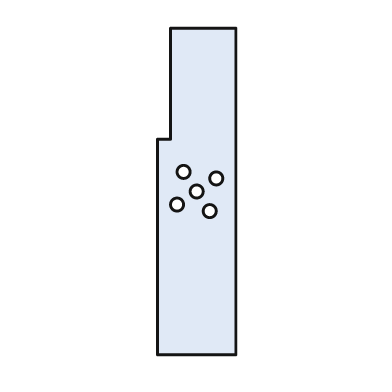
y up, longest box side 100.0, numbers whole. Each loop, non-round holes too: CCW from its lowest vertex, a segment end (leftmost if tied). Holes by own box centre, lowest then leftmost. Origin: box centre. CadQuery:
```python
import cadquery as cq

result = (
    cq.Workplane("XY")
    .moveTo(-12.0, -50.0)
    .lineTo(12.0, -50.0)
    .lineTo(12.0, 50.0)
    .lineTo(-8.0, 50.0)
    .lineTo(-8.0, 16.0)
    .lineTo(-12.0, 16.0)
    .close()
    .moveTo(4.0, -6.0)
    .circle(2.0)
    .moveTo(-6.0, -4.0)
    .circle(2.0)
    .moveTo(0.0, 0.0)
    .circle(2.0)
    .moveTo(6.0, 4.0)
    .circle(2.0)
    .moveTo(-4.0, 6.0)
    .circle(2.0)
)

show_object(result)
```